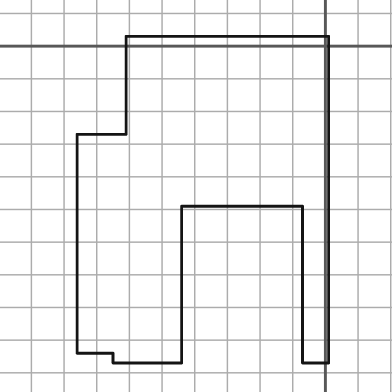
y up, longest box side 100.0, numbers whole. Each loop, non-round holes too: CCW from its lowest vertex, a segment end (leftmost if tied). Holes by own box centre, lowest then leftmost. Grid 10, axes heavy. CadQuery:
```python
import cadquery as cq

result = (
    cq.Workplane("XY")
    .moveTo(-65.0, -97.0)
    .lineTo(-44.0, -97.0)
    .lineTo(-44.0, -49.0)
    .lineTo(-7.0, -49.0)
    .lineTo(-7.0, -97.0)
    .lineTo(1.0, -97.0)
    .lineTo(1.0, 3.0)
    .lineTo(-61.0, 3.0)
    .lineTo(-61.0, -27.0)
    .lineTo(-76.0, -27.0)
    .lineTo(-76.0, -94.0)
    .lineTo(-65.0, -94.0)
    .close()
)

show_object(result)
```